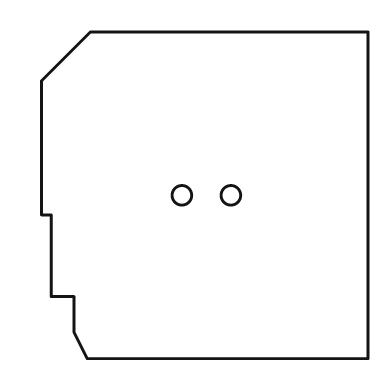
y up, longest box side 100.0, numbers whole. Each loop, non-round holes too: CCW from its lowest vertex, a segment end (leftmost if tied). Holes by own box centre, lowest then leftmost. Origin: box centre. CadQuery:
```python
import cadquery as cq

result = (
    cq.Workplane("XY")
    .moveTo(-36.0, -50.0)
    .lineTo(50.0, -50.0)
    .lineTo(50.0, 50.0)
    .lineTo(-35.0, 50.0)
    .lineTo(-50.0, 35.0)
    .lineTo(-50.0, -6.0)
    .lineTo(-47.0, -6.0)
    .lineTo(-47.0, -31.0)
    .lineTo(-40.0, -31.0)
    .lineTo(-40.0, -42.0)
    .close()
    .moveTo(-7.0, 0.0)
    .circle(3.0)
    .moveTo(8.0, 0.0)
    .circle(3.0)
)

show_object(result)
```